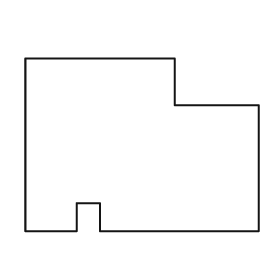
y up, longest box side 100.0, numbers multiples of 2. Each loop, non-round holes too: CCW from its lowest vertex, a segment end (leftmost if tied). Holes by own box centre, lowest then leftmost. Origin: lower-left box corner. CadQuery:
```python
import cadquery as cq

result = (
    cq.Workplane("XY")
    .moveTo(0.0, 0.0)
    .lineTo(22.0, 0.0)
    .lineTo(22.0, 12.0)
    .lineTo(32.0, 12.0)
    .lineTo(32.0, 0.0)
    .lineTo(100.0, 0.0)
    .lineTo(100.0, 54.0)
    .lineTo(64.0, 54.0)
    .lineTo(64.0, 74.0)
    .lineTo(0.0, 74.0)
    .close()
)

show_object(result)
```